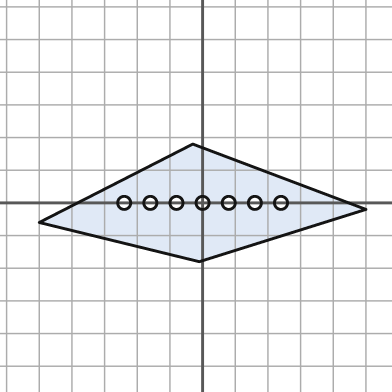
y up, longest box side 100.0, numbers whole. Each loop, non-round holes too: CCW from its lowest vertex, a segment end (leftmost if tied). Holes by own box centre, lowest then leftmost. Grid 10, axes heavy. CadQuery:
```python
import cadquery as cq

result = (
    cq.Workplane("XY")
    .moveTo(-1.0, -18.0)
    .lineTo(50.0, -2.0)
    .lineTo(-3.0, 18.0)
    .lineTo(-50.0, -6.0)
    .close()
    .moveTo(-24.0, 0.0)
    .circle(2.0)
    .moveTo(-16.0, 0.0)
    .circle(2.0)
    .moveTo(-8.0, 0.0)
    .circle(2.0)
    .moveTo(0.0, 0.0)
    .circle(2.0)
    .moveTo(8.0, 0.0)
    .circle(2.0)
    .moveTo(16.0, 0.0)
    .circle(2.0)
    .moveTo(24.0, 0.0)
    .circle(2.0)
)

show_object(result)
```